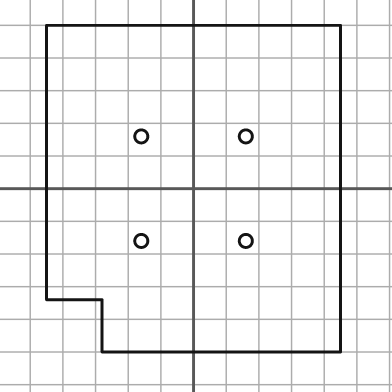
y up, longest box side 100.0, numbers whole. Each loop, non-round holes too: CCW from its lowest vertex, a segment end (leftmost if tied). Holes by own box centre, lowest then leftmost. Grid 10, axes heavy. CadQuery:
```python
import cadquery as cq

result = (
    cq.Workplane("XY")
    .moveTo(-28.0, -50.0)
    .lineTo(45.0, -50.0)
    .lineTo(45.0, 50.0)
    .lineTo(-45.0, 50.0)
    .lineTo(-45.0, -34.0)
    .lineTo(-28.0, -34.0)
    .close()
    .moveTo(-16.0, -16.0)
    .circle(2.0)
    .moveTo(16.0, -16.0)
    .circle(2.0)
    .moveTo(-16.0, 16.0)
    .circle(2.0)
    .moveTo(16.0, 16.0)
    .circle(2.0)
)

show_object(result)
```